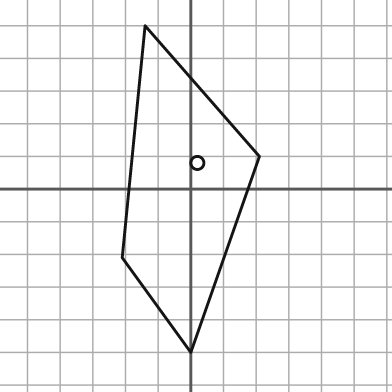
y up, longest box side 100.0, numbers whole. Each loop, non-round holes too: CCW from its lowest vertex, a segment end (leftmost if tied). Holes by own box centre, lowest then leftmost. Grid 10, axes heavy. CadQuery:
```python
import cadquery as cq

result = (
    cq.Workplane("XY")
    .moveTo(0.0, -50.0)
    .lineTo(21.0, 10.0)
    .lineTo(-14.0, 50.0)
    .lineTo(-21.0, -21.0)
    .close()
    .moveTo(2.0, 8.0)
    .circle(2.0)
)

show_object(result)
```